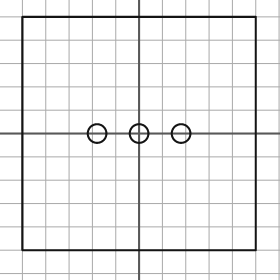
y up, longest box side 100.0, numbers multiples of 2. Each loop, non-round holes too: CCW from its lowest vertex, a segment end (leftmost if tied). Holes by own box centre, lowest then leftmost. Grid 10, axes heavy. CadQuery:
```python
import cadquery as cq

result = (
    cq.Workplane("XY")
    .moveTo(-50.0, -50.0)
    .lineTo(50.0, -50.0)
    .lineTo(50.0, 50.0)
    .lineTo(-50.0, 50.0)
    .close()
    .moveTo(-18.0, 0.0)
    .circle(4.0)
    .moveTo(0.0, 0.0)
    .circle(4.0)
    .moveTo(18.0, 0.0)
    .circle(4.0)
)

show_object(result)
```